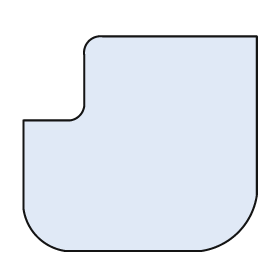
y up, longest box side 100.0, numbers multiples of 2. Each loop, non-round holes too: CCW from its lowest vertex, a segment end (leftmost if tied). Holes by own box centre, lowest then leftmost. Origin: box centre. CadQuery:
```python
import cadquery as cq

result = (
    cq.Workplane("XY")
    .moveTo(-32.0, -46.0)
    .lineTo(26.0, -46.0)
    .threePointArc((42.0, -38.0), (50.0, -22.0))
    .lineTo(50.0, 46.0)
    .lineTo(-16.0, 46.0)
    .threePointArc((-22.0, 44.0), (-24.0, 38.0))
    .lineTo(-24.0, 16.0)
    .threePointArc((-26.0, 12.0), (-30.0, 10.0))
    .lineTo(-50.0, 10.0)
    .lineTo(-50.0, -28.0)
    .threePointArc((-44.0, -40.0), (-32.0, -46.0))
    .close()
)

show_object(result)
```